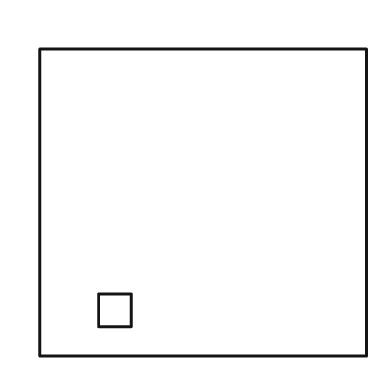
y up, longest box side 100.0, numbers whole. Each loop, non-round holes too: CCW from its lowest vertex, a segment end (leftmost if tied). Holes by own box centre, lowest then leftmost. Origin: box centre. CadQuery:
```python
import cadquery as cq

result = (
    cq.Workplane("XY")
    .moveTo(-50.0, -47.0)
    .lineTo(50.0, -47.0)
    .lineTo(50.0, 47.0)
    .lineTo(-50.0, 47.0)
    .close()
    .moveTo(-32.0, -38.0)
    .lineTo(-22.0, -38.0)
    .lineTo(-22.0, -28.0)
    .lineTo(-32.0, -28.0)
    .close()
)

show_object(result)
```